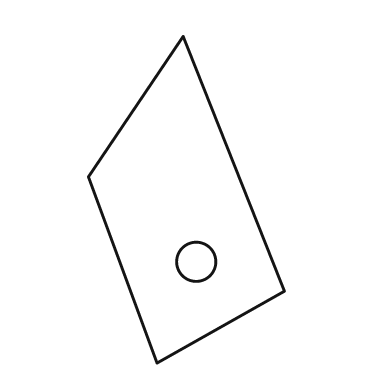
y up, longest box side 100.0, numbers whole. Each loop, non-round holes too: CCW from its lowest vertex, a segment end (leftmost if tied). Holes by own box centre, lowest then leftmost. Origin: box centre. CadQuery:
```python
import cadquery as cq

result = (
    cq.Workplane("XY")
    .moveTo(-9.0, -50.0)
    .lineTo(30.0, -28.0)
    .lineTo(-1.0, 50.0)
    .lineTo(-30.0, 7.0)
    .close()
    .moveTo(3.0, -19.0)
    .circle(6.0)
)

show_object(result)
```